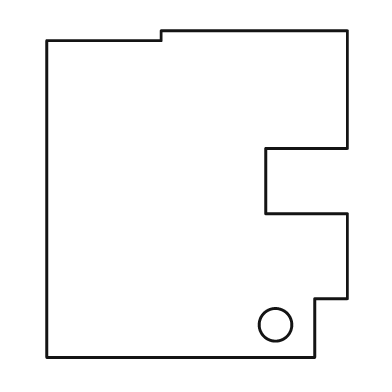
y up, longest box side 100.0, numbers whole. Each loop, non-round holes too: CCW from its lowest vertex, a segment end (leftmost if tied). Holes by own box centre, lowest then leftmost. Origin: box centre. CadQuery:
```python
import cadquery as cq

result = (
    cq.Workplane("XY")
    .moveTo(-46.0, -50.0)
    .lineTo(36.0, -50.0)
    .lineTo(36.0, -32.0)
    .lineTo(46.0, -32.0)
    .lineTo(46.0, -6.0)
    .lineTo(21.0, -6.0)
    .lineTo(21.0, 14.0)
    .lineTo(46.0, 14.0)
    .lineTo(46.0, 50.0)
    .lineTo(-11.0, 50.0)
    .lineTo(-11.0, 47.0)
    .lineTo(-46.0, 47.0)
    .close()
    .moveTo(24.0, -40.0)
    .circle(5.0)
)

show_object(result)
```